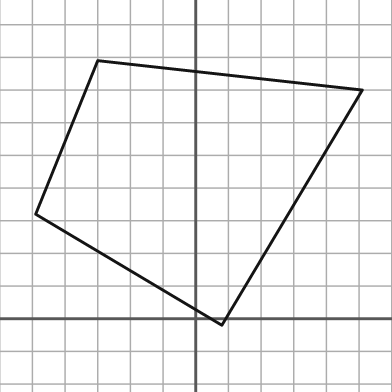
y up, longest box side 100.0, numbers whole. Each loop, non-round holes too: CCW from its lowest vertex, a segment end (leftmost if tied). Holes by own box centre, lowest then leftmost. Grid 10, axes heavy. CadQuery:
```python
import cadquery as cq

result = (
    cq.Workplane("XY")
    .moveTo(8.0, -2.0)
    .lineTo(51.0, 70.0)
    .lineTo(-30.0, 79.0)
    .lineTo(-49.0, 32.0)
    .close()
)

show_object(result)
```